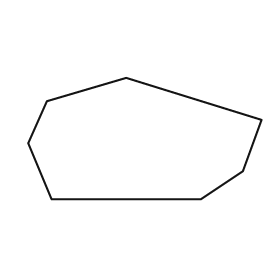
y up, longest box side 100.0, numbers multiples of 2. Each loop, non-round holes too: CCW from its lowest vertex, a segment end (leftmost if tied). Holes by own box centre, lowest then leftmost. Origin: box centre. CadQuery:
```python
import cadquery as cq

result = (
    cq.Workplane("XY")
    .moveTo(-40.0, -26.0)
    .lineTo(24.0, -26.0)
    .lineTo(42.0, -14.0)
    .lineTo(50.0, 8.0)
    .lineTo(-8.0, 26.0)
    .lineTo(-42.0, 16.0)
    .lineTo(-50.0, -2.0)
    .close()
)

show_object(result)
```